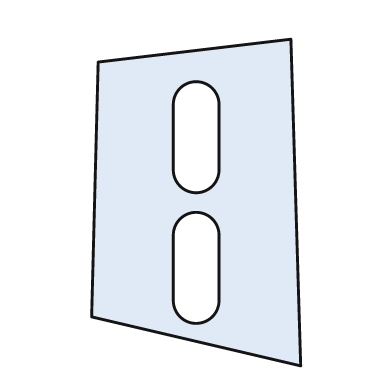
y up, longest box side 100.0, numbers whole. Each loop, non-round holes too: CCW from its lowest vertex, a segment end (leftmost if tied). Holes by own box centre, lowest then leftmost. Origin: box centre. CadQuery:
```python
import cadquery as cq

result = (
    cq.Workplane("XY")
    .moveTo(32.0, -50.0)
    .lineTo(29.0, 50.0)
    .lineTo(-30.0, 43.0)
    .lineTo(-32.0, -35.0)
    .close()
    .moveTo(-7.0, -30.0)
    .threePointArc((0.0, -37.0), (7.0, -30.0))
    .lineTo(7.0, -10.0)
    .threePointArc((0.0, -3.0), (-7.0, -10.0))
    .close()
    .moveTo(-7.0, 10.0)
    .threePointArc((0.0, 3.0), (7.0, 10.0))
    .lineTo(7.0, 30.0)
    .threePointArc((0.0, 37.0), (-7.0, 30.0))
    .close()
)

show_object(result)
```